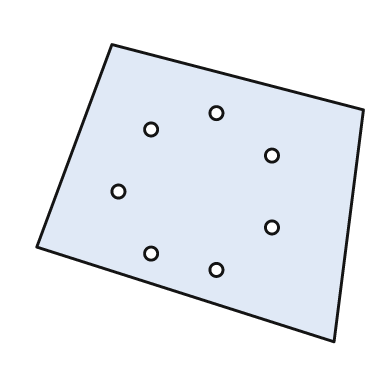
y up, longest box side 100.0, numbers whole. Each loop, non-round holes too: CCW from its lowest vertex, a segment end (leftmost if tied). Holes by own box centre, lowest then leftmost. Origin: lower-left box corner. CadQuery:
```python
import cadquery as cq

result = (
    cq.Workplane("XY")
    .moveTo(91.0, 0.0)
    .lineTo(100.0, 71.0)
    .lineTo(23.0, 91.0)
    .lineTo(0.0, 29.0)
    .close()
    .moveTo(55.0, 22.0)
    .circle(2.0)
    .moveTo(35.0, 27.0)
    .circle(2.0)
    .moveTo(72.0, 35.0)
    .circle(2.0)
    .moveTo(25.0, 46.0)
    .circle(2.0)
    .moveTo(72.0, 57.0)
    .circle(2.0)
    .moveTo(35.0, 65.0)
    .circle(2.0)
    .moveTo(55.0, 70.0)
    .circle(2.0)
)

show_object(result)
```